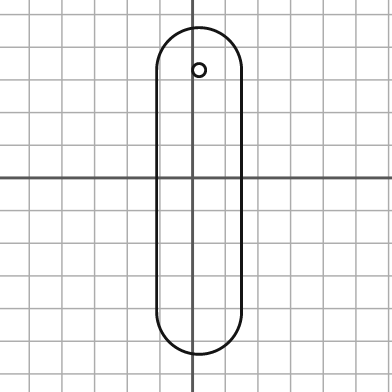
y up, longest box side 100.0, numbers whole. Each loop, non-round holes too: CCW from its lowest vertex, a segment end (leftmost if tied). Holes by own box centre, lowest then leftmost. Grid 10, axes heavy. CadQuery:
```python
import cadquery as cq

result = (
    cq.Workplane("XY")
    .moveTo(-11.0, -41.0)
    .threePointArc((2.0, -54.0), (15.0, -41.0))
    .lineTo(15.0, 33.0)
    .threePointArc((2.0, 46.0), (-11.0, 33.0))
    .close()
    .moveTo(2.0, 33.0)
    .circle(2.0)
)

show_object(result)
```